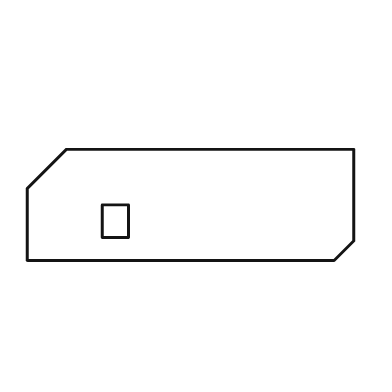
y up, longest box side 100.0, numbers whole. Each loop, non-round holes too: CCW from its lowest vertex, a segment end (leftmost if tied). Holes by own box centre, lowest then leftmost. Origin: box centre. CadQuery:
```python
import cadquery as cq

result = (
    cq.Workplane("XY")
    .moveTo(-50.0, -17.0)
    .lineTo(44.0, -17.0)
    .lineTo(50.0, -11.0)
    .lineTo(50.0, 17.0)
    .lineTo(-38.0, 17.0)
    .lineTo(-50.0, 5.0)
    .close()
    .moveTo(-27.0, -10.0)
    .lineTo(-19.0, -10.0)
    .lineTo(-19.0, 0.0)
    .lineTo(-27.0, 0.0)
    .close()
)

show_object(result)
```